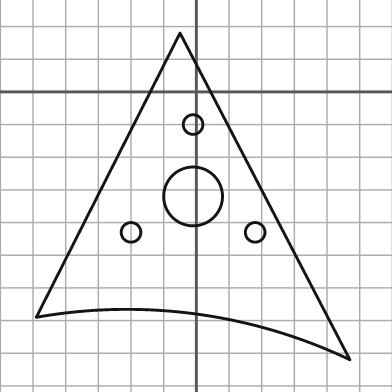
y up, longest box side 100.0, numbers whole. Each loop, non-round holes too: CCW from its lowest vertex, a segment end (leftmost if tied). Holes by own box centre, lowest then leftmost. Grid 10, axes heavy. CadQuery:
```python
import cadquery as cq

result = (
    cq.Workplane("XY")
    .moveTo(47.0, -82.0)
    .lineTo(-5.0, 18.0)
    .lineTo(-49.0, -69.0)
    .threePointArc((0.0, -68.0), (47.0, -82.0))
    .close()
    .moveTo(-20.0, -43.0)
    .circle(3.0)
    .moveTo(18.0, -43.0)
    .circle(3.0)
    .moveTo(-1.0, -32.0)
    .circle(9.0)
    .moveTo(-1.0, -10.0)
    .circle(3.0)
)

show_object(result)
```